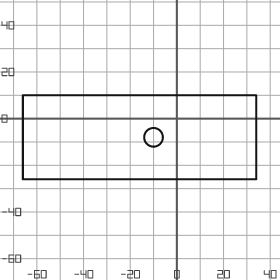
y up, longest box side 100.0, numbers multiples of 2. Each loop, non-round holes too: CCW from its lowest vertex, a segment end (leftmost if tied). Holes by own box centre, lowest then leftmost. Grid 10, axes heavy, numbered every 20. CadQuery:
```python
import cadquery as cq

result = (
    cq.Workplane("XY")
    .moveTo(-66.0, -26.0)
    .lineTo(34.0, -26.0)
    .lineTo(34.0, 10.0)
    .lineTo(-66.0, 10.0)
    .close()
    .moveTo(-10.0, -8.0)
    .circle(4.0)
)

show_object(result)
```